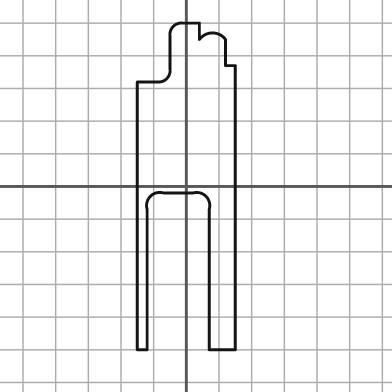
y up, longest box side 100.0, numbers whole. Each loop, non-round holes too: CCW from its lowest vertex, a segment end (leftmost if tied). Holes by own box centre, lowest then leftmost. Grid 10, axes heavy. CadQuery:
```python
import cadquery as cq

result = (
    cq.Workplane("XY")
    .moveTo(-15.0, -50.0)
    .lineTo(-12.0, -50.0)
    .lineTo(-12.0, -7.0)
    .threePointArc((-11.0, -3.0), (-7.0, -2.0))
    .lineTo(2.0, -2.0)
    .threePointArc((6.0, -3.0), (7.0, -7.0))
    .lineTo(7.0, -50.0)
    .lineTo(15.0, -50.0)
    .lineTo(15.0, 37.0)
    .lineTo(12.0, 37.0)
    .lineTo(12.0, 45.0)
    .threePointArc((8.0, 47.0), (4.0, 45.0))
    .lineTo(4.0, 50.0)
    .lineTo(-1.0, 50.0)
    .threePointArc((-4.0, 49.0), (-5.0, 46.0))
    .lineTo(-5.0, 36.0)
    .threePointArc((-6.0, 33.0), (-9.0, 32.0))
    .lineTo(-15.0, 32.0)
    .close()
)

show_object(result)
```